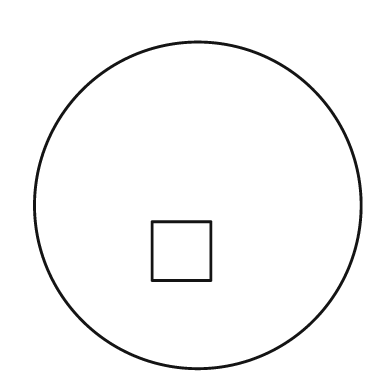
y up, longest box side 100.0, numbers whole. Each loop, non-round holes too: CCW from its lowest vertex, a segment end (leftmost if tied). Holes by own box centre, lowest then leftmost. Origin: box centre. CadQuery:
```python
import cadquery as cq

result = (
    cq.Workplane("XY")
    .moveTo(0.0, 0.0)
    .circle(50.0)
    .moveTo(-14.0, -23.0)
    .lineTo(4.0, -23.0)
    .lineTo(4.0, -5.0)
    .lineTo(-14.0, -5.0)
    .close()
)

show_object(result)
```